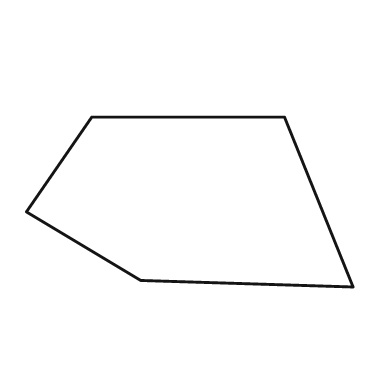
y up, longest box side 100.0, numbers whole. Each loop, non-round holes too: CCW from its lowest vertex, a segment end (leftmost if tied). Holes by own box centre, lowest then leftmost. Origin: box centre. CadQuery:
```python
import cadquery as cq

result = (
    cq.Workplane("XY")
    .moveTo(50.0, -26.0)
    .lineTo(29.0, 26.0)
    .lineTo(-30.0, 26.0)
    .lineTo(-50.0, -3.0)
    .lineTo(-15.0, -24.0)
    .close()
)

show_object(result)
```